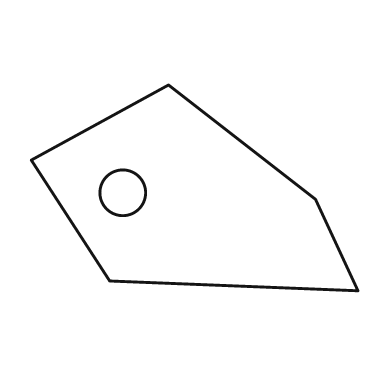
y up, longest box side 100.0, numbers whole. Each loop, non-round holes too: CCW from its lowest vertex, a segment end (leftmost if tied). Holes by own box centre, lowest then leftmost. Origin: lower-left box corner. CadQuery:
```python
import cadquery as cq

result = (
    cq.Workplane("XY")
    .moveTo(100.0, 0.0)
    .lineTo(87.0, 28.0)
    .lineTo(42.0, 63.0)
    .lineTo(0.0, 40.0)
    .lineTo(24.0, 3.0)
    .close()
    .moveTo(28.0, 30.0)
    .circle(7.0)
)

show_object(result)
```